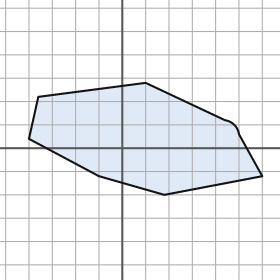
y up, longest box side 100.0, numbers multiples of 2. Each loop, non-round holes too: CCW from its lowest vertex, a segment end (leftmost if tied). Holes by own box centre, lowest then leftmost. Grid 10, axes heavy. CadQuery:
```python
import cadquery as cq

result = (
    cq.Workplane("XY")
    .moveTo(18.0, -20.0)
    .lineTo(60.0, -12.0)
    .lineTo(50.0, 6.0)
    .threePointArc((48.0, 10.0), (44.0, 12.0))
    .lineTo(10.0, 28.0)
    .lineTo(-36.0, 22.0)
    .lineTo(-40.0, 4.0)
    .lineTo(-10.0, -12.0)
    .close()
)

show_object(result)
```